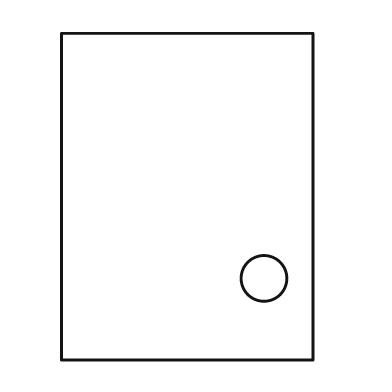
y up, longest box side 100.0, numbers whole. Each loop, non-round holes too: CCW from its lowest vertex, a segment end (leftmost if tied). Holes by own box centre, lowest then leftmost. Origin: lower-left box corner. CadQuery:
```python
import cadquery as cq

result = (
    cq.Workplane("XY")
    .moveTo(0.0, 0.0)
    .lineTo(77.0, 0.0)
    .lineTo(77.0, 100.0)
    .lineTo(0.0, 100.0)
    .close()
    .moveTo(62.0, 25.0)
    .circle(7.0)
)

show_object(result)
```